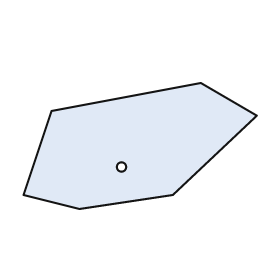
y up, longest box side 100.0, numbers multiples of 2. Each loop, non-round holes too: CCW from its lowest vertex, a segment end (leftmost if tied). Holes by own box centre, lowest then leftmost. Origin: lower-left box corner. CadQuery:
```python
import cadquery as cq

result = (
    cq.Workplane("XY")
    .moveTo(24.0, 0.0)
    .lineTo(64.0, 6.0)
    .lineTo(100.0, 40.0)
    .lineTo(76.0, 54.0)
    .lineTo(12.0, 42.0)
    .lineTo(0.0, 6.0)
    .close()
    .moveTo(42.0, 18.0)
    .circle(2.0)
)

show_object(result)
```